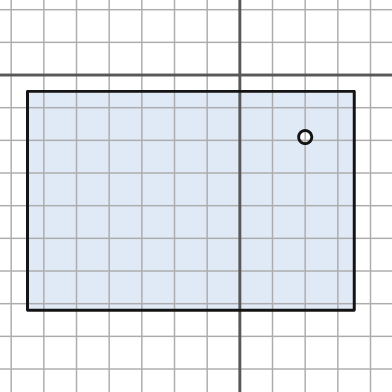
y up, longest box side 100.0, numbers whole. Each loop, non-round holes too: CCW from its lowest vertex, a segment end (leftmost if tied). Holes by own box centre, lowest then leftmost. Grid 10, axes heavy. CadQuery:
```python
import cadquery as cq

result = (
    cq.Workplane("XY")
    .moveTo(-65.0, -72.0)
    .lineTo(35.0, -72.0)
    .lineTo(35.0, -5.0)
    .lineTo(-65.0, -5.0)
    .close()
    .moveTo(20.0, -19.0)
    .circle(2.0)
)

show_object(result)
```